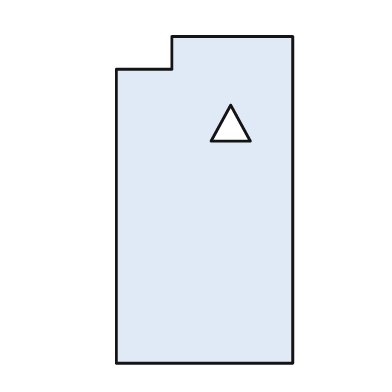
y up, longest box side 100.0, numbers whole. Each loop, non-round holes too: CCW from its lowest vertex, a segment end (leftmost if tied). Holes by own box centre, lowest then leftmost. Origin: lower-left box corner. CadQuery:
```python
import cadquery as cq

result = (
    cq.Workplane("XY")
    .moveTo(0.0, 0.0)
    .lineTo(54.0, 0.0)
    .lineTo(54.0, 100.0)
    .lineTo(17.0, 100.0)
    .lineTo(17.0, 90.0)
    .lineTo(0.0, 90.0)
    .close()
    .moveTo(29.0, 68.0)
    .lineTo(41.0, 68.0)
    .lineTo(35.0, 79.0)
    .close()
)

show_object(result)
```